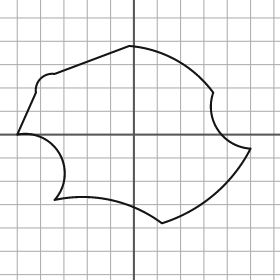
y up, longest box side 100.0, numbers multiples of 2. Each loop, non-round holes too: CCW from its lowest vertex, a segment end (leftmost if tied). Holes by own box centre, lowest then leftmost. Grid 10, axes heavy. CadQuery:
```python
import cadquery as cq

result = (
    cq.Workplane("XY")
    .moveTo(12.0, -38.0)
    .threePointArc((34.0, -26.0), (50.0, -6.0))
    .threePointArc((36.0, 2.0), (34.0, 18.0))
    .threePointArc((18.0, 32.0), (-2.0, 38.0))
    .lineTo(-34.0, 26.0)
    .threePointArc((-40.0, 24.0), (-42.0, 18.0))
    .lineTo(-50.0, 0.0)
    .threePointArc((-32.0, -8.0), (-34.0, -28.0))
    .threePointArc((-10.0, -28.0), (12.0, -38.0))
    .close()
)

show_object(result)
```